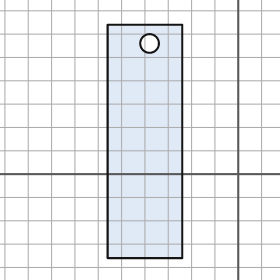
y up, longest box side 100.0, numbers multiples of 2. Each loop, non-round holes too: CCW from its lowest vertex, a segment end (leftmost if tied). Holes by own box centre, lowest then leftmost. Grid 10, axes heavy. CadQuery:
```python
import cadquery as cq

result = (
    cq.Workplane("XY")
    .moveTo(-56.0, -36.0)
    .lineTo(-24.0, -36.0)
    .lineTo(-24.0, 64.0)
    .lineTo(-56.0, 64.0)
    .close()
    .moveTo(-38.0, 56.0)
    .circle(4.0)
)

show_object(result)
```